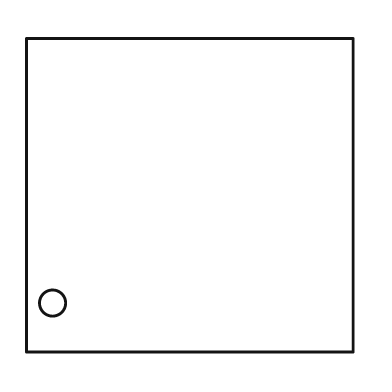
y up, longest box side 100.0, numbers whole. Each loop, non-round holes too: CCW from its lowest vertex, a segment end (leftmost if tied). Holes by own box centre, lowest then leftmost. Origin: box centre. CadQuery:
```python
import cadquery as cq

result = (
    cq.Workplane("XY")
    .moveTo(-50.0, -48.0)
    .lineTo(50.0, -48.0)
    .lineTo(50.0, 48.0)
    .lineTo(-50.0, 48.0)
    .close()
    .moveTo(-42.0, -33.0)
    .circle(4.0)
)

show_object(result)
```